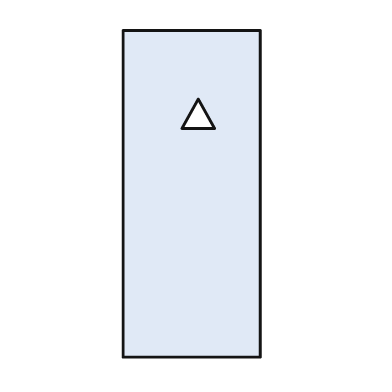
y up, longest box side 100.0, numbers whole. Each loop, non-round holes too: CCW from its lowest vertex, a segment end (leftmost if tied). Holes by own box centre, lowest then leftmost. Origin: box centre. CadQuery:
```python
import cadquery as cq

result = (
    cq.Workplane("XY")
    .moveTo(-21.0, -50.0)
    .lineTo(21.0, -50.0)
    .lineTo(21.0, 50.0)
    .lineTo(-21.0, 50.0)
    .close()
    .moveTo(-3.0, 20.0)
    .lineTo(7.0, 20.0)
    .lineTo(2.0, 29.0)
    .close()
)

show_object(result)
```